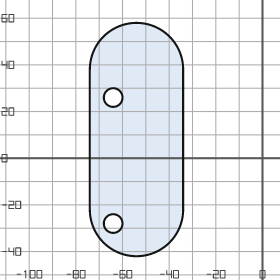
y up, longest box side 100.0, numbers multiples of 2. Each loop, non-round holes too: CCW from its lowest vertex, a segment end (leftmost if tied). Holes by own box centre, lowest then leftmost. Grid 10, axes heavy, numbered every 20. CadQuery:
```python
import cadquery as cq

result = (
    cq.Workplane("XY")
    .moveTo(-74.0, -22.0)
    .threePointArc((-54.0, -42.0), (-34.0, -22.0))
    .lineTo(-34.0, 38.0)
    .threePointArc((-54.0, 58.0), (-74.0, 38.0))
    .close()
    .moveTo(-64.0, -28.0)
    .circle(4.0)
    .moveTo(-64.0, 26.0)
    .circle(4.0)
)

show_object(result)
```